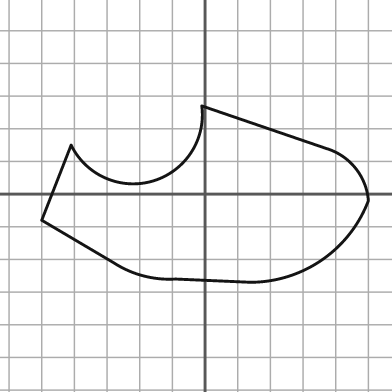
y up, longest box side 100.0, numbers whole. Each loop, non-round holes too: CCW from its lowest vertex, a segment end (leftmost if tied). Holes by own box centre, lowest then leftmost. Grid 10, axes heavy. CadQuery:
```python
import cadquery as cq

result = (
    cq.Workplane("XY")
    .moveTo(14.0, -27.0)
    .threePointArc((36.0, -20.0), (50.0, -2.0))
    .threePointArc((46.0, 8.0), (37.0, 14.0))
    .lineTo(-1.0, 27.0)
    .threePointArc((-16.0, 4.0), (-41.0, 15.0))
    .lineTo(-50.0, -8.0)
    .lineTo(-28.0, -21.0)
    .threePointArc((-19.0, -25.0), (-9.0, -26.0))
    .close()
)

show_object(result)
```